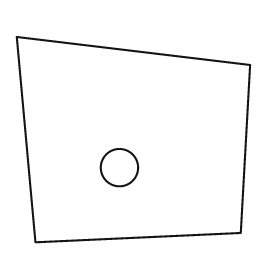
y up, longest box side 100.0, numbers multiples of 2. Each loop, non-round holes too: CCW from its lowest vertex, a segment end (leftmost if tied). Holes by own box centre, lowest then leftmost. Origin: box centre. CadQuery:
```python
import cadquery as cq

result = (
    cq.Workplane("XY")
    .moveTo(-42.0, -44.0)
    .lineTo(46.0, -40.0)
    .lineTo(50.0, 32.0)
    .lineTo(-50.0, 44.0)
    .close()
    .moveTo(-6.0, -12.0)
    .circle(8.0)
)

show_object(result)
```